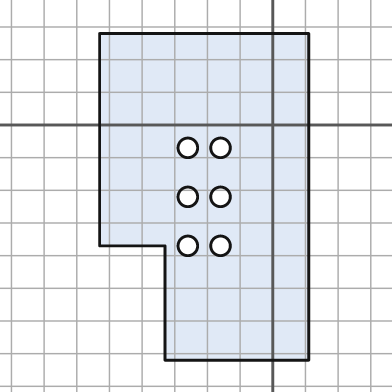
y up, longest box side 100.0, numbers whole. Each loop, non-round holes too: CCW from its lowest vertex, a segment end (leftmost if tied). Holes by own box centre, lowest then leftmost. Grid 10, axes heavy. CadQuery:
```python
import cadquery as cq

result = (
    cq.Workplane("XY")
    .moveTo(-33.0, -72.0)
    .lineTo(11.0, -72.0)
    .lineTo(11.0, 28.0)
    .lineTo(-53.0, 28.0)
    .lineTo(-53.0, -37.0)
    .lineTo(-33.0, -37.0)
    .close()
    .moveTo(-26.0, -37.0)
    .circle(3.0)
    .moveTo(-16.0, -37.0)
    .circle(3.0)
    .moveTo(-26.0, -22.0)
    .circle(3.0)
    .moveTo(-16.0, -22.0)
    .circle(3.0)
    .moveTo(-26.0, -7.0)
    .circle(3.0)
    .moveTo(-16.0, -7.0)
    .circle(3.0)
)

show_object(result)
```